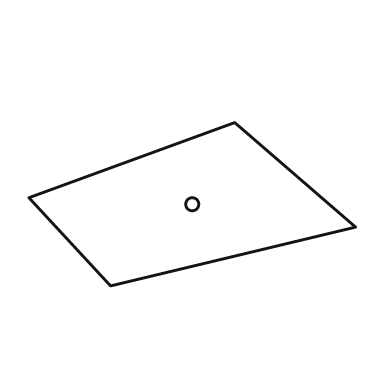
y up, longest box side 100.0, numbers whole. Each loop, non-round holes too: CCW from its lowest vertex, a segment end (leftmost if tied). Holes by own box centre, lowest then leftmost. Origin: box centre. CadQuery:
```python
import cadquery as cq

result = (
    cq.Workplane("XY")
    .moveTo(-25.0, -25.0)
    .lineTo(50.0, -7.0)
    .lineTo(13.0, 25.0)
    .lineTo(-50.0, 2.0)
    .close()
    .moveTo(0.0, 0.0)
    .circle(2.0)
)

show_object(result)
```